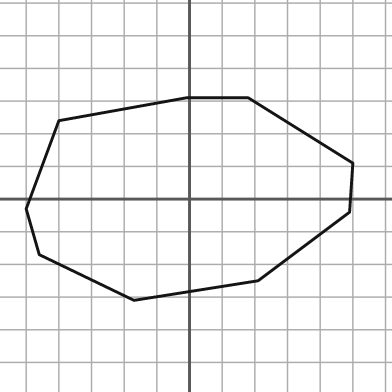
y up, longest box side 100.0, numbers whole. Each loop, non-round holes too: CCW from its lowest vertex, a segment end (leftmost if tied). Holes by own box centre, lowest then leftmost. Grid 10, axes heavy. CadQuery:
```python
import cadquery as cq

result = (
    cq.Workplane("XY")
    .moveTo(-17.0, -31.0)
    .lineTo(21.0, -25.0)
    .lineTo(49.0, -4.0)
    .lineTo(50.0, 11.0)
    .lineTo(18.0, 31.0)
    .lineTo(-1.0, 31.0)
    .lineTo(-40.0, 24.0)
    .lineTo(-50.0, -3.0)
    .lineTo(-46.0, -17.0)
    .close()
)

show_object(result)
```